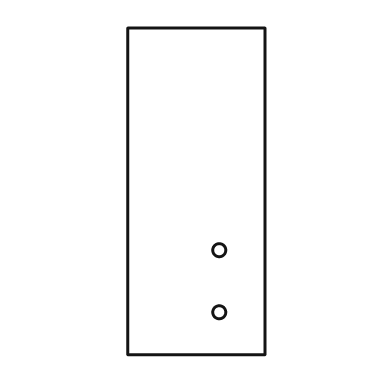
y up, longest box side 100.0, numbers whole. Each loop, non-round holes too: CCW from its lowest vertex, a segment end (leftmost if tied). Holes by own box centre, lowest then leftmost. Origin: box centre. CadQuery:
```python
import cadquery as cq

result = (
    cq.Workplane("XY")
    .moveTo(-21.0, -50.0)
    .lineTo(21.0, -50.0)
    .lineTo(21.0, 50.0)
    .lineTo(-21.0, 50.0)
    .close()
    .moveTo(7.0, -37.0)
    .circle(2.0)
    .moveTo(7.0, -18.0)
    .circle(2.0)
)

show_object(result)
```